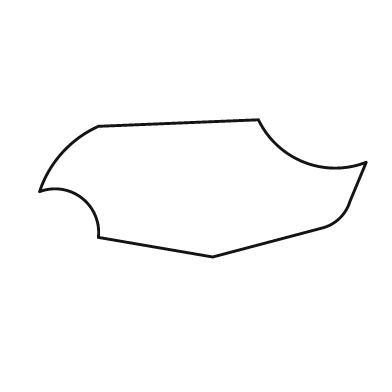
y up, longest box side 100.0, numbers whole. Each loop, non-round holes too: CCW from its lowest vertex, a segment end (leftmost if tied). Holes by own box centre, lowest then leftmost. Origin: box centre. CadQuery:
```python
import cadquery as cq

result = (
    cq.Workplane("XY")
    .moveTo(3.0, -21.0)
    .lineTo(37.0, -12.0)
    .threePointArc((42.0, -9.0), (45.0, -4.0))
    .lineTo(50.0, 8.0)
    .threePointArc((31.0, 8.0), (17.0, 21.0))
    .lineTo(-32.0, 19.0)
    .threePointArc((-43.0, 11.0), (-50.0, -1.0))
    .threePointArc((-37.0, -3.0), (-32.0, -15.0))
    .close()
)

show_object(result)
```